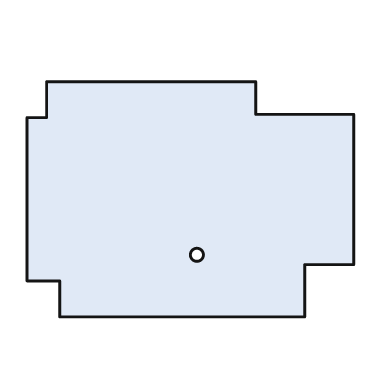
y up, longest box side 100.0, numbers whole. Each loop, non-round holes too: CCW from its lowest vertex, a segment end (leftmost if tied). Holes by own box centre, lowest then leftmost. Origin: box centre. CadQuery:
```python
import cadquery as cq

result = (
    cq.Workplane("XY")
    .moveTo(-40.0, -36.0)
    .lineTo(35.0, -36.0)
    .lineTo(35.0, -20.0)
    .lineTo(50.0, -20.0)
    .lineTo(50.0, 26.0)
    .lineTo(20.0, 26.0)
    .lineTo(20.0, 36.0)
    .lineTo(-44.0, 36.0)
    .lineTo(-44.0, 25.0)
    .lineTo(-50.0, 25.0)
    .lineTo(-50.0, -25.0)
    .lineTo(-40.0, -25.0)
    .close()
    .moveTo(2.0, -17.0)
    .circle(2.0)
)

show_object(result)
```